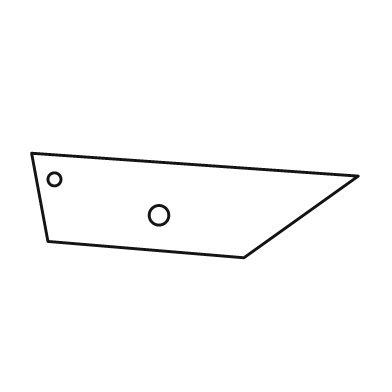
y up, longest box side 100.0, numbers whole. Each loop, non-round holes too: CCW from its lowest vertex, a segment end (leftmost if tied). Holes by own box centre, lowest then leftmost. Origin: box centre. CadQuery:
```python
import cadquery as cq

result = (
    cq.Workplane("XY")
    .moveTo(15.0, -16.0)
    .lineTo(50.0, 9.0)
    .lineTo(-50.0, 16.0)
    .lineTo(-45.0, -11.0)
    .close()
    .moveTo(-11.0, -3.0)
    .circle(3.0)
    .moveTo(-43.0, 8.0)
    .circle(2.0)
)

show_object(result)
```